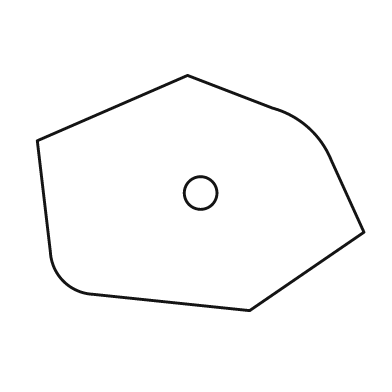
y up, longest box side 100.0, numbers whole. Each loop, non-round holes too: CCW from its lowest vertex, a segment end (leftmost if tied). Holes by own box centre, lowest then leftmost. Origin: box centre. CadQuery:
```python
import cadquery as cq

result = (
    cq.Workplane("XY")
    .moveTo(15.0, -36.0)
    .lineTo(50.0, -12.0)
    .lineTo(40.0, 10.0)
    .threePointArc((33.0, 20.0), (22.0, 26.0))
    .lineTo(-4.0, 36.0)
    .lineTo(-50.0, 16.0)
    .lineTo(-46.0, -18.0)
    .threePointArc((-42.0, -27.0), (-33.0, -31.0))
    .close()
    .moveTo(0.0, 0.0)
    .circle(5.0)
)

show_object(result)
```